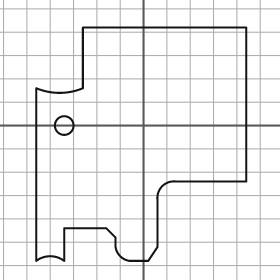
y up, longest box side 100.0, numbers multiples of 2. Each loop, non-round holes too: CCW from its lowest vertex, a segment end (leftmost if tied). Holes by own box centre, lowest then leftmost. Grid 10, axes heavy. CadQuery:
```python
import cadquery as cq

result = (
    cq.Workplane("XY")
    .moveTo(-46.0, -58.0)
    .threePointArc((-40.0, -56.0), (-34.0, -58.0))
    .lineTo(-34.0, -44.0)
    .lineTo(-16.0, -44.0)
    .lineTo(-12.0, -48.0)
    .lineTo(-12.0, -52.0)
    .threePointArc((-10.0, -56.0), (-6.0, -58.0))
    .lineTo(2.0, -58.0)
    .lineTo(6.0, -52.0)
    .lineTo(6.0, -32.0)
    .threePointArc((8.0, -26.0), (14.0, -24.0))
    .lineTo(44.0, -24.0)
    .lineTo(44.0, 42.0)
    .lineTo(-26.0, 42.0)
    .lineTo(-26.0, 16.0)
    .threePointArc((-36.0, 14.0), (-46.0, 16.0))
    .close()
    .moveTo(-34.0, 0.0)
    .circle(4.0)
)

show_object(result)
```